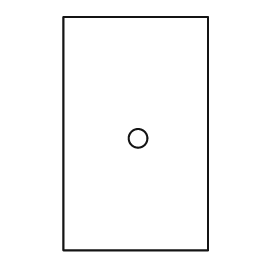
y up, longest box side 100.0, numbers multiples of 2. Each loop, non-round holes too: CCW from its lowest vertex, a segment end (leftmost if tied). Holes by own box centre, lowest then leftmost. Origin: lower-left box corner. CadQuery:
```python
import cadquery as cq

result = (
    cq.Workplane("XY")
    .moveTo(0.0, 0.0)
    .lineTo(62.0, 0.0)
    .lineTo(62.0, 100.0)
    .lineTo(0.0, 100.0)
    .close()
    .moveTo(32.0, 48.0)
    .circle(4.0)
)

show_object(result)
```